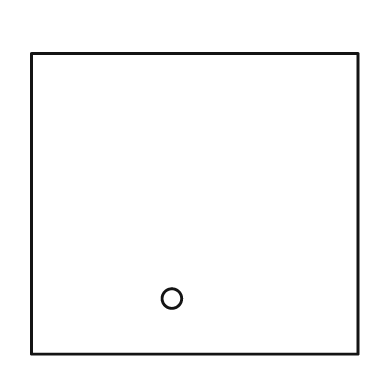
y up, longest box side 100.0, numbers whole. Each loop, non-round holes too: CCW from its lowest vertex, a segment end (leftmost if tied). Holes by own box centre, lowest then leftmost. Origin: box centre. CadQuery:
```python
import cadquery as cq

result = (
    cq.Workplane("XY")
    .moveTo(-50.0, -46.0)
    .lineTo(50.0, -46.0)
    .lineTo(50.0, 46.0)
    .lineTo(-50.0, 46.0)
    .close()
    .moveTo(-7.0, -29.0)
    .circle(3.0)
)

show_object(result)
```